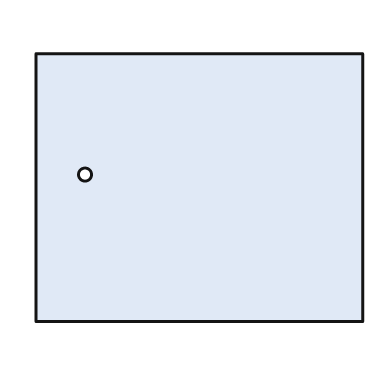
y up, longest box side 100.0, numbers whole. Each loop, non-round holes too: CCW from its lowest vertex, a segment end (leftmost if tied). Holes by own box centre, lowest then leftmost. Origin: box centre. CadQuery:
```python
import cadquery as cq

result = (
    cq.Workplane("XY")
    .moveTo(-50.0, -41.0)
    .lineTo(50.0, -41.0)
    .lineTo(50.0, 41.0)
    .lineTo(-50.0, 41.0)
    .close()
    .moveTo(-35.0, 4.0)
    .circle(2.0)
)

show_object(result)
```